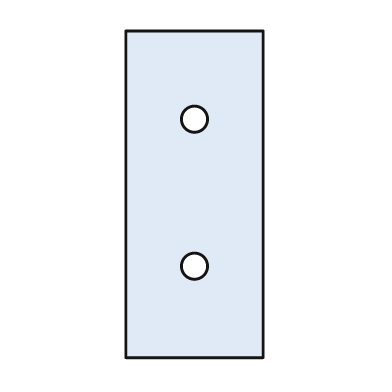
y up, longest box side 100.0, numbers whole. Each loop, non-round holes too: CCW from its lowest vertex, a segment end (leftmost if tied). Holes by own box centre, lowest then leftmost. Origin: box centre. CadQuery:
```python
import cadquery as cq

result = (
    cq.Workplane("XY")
    .moveTo(-21.0, -50.0)
    .lineTo(21.0, -50.0)
    .lineTo(21.0, 50.0)
    .lineTo(-21.0, 50.0)
    .close()
    .moveTo(0.0, -22.0)
    .circle(4.0)
    .moveTo(0.0, 23.0)
    .circle(4.0)
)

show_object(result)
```